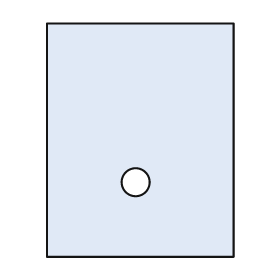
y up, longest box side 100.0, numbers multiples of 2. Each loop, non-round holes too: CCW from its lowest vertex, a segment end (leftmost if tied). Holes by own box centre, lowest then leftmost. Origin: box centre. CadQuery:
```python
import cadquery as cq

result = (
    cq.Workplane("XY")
    .moveTo(-40.0, -50.0)
    .lineTo(40.0, -50.0)
    .lineTo(40.0, 50.0)
    .lineTo(-40.0, 50.0)
    .close()
    .moveTo(-2.0, -18.0)
    .circle(6.0)
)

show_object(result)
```